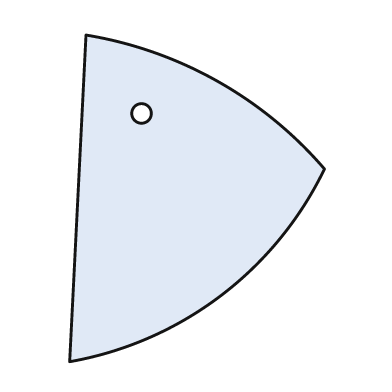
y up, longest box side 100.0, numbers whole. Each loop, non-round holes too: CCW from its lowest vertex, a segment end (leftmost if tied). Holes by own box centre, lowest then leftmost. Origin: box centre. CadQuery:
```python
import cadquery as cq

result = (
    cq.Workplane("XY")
    .moveTo(-39.0, -50.0)
    .threePointArc((7.0, -30.0), (39.0, 9.0))
    .threePointArc((6.0, 36.0), (-34.0, 50.0))
    .close()
    .moveTo(-17.0, 26.0)
    .circle(3.0)
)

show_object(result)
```